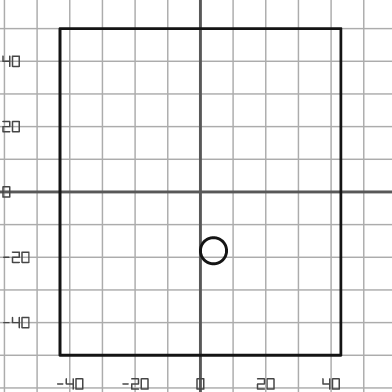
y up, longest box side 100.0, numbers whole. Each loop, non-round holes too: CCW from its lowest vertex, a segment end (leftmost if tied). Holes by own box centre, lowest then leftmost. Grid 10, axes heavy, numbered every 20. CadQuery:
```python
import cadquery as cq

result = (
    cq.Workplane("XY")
    .moveTo(-43.0, -50.0)
    .lineTo(43.0, -50.0)
    .lineTo(43.0, 50.0)
    .lineTo(-43.0, 50.0)
    .close()
    .moveTo(4.0, -18.0)
    .circle(4.0)
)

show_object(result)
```